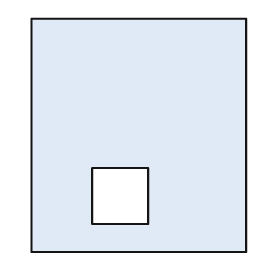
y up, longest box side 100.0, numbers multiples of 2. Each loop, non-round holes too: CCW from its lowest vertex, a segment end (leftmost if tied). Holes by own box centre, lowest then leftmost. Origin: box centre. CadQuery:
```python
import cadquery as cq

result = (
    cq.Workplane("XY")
    .moveTo(-46.0, -50.0)
    .lineTo(46.0, -50.0)
    .lineTo(46.0, 50.0)
    .lineTo(-46.0, 50.0)
    .close()
    .moveTo(-20.0, -38.0)
    .lineTo(4.0, -38.0)
    .lineTo(4.0, -14.0)
    .lineTo(-20.0, -14.0)
    .close()
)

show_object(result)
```